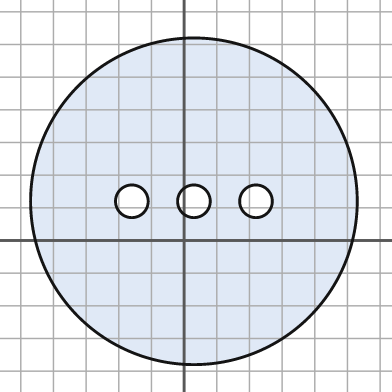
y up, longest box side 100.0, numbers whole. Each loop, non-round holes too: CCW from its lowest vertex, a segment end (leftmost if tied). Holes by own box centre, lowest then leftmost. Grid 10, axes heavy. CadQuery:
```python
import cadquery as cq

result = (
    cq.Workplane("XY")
    .moveTo(3.0, 12.0)
    .circle(50.0)
    .moveTo(-16.0, 12.0)
    .circle(5.0)
    .moveTo(3.0, 12.0)
    .circle(5.0)
    .moveTo(22.0, 12.0)
    .circle(5.0)
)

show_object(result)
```